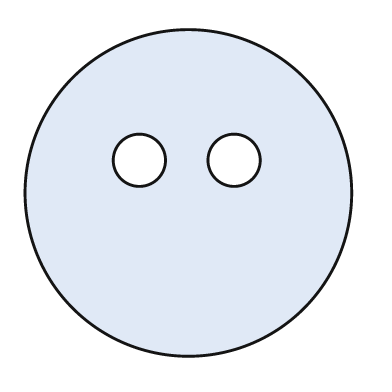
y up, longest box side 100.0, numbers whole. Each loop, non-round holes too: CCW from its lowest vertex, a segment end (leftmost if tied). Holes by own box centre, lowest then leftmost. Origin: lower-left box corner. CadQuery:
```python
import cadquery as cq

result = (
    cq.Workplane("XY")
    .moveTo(50.0, 50.0)
    .circle(50.0)
    .moveTo(35.0, 60.0)
    .circle(8.0)
    .moveTo(64.0, 60.0)
    .circle(8.0)
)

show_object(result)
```